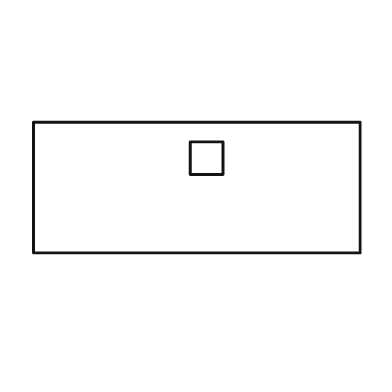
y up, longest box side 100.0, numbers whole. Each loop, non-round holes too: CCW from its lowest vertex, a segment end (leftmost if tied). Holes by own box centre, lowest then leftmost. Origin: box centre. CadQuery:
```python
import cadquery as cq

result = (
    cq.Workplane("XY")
    .moveTo(-50.0, -20.0)
    .lineTo(50.0, -20.0)
    .lineTo(50.0, 20.0)
    .lineTo(-50.0, 20.0)
    .close()
    .moveTo(-2.0, 4.0)
    .lineTo(8.0, 4.0)
    .lineTo(8.0, 14.0)
    .lineTo(-2.0, 14.0)
    .close()
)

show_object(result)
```